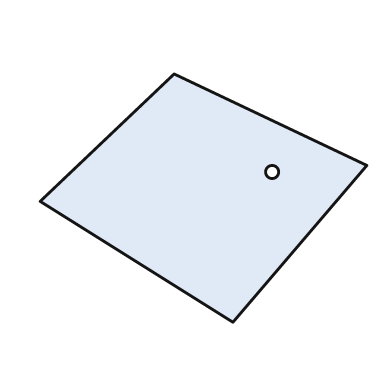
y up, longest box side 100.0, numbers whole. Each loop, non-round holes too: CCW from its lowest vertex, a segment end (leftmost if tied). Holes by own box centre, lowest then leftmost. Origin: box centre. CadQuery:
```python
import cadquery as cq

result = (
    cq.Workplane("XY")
    .moveTo(9.0, -38.0)
    .lineTo(50.0, 10.0)
    .lineTo(-9.0, 38.0)
    .lineTo(-50.0, -1.0)
    .close()
    .moveTo(21.0, 8.0)
    .circle(2.0)
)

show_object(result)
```